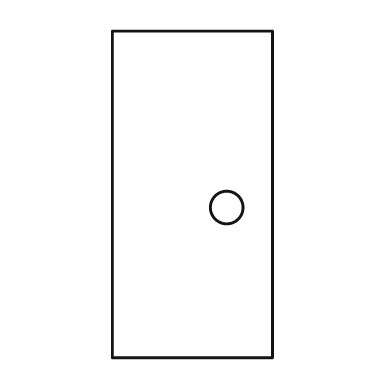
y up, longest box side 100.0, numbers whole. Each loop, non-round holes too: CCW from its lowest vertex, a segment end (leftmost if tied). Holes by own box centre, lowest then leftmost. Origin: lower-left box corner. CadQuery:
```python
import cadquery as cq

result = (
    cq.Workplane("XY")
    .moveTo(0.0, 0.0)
    .lineTo(49.0, 0.0)
    .lineTo(49.0, 100.0)
    .lineTo(0.0, 100.0)
    .close()
    .moveTo(35.0, 46.0)
    .circle(5.0)
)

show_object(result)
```